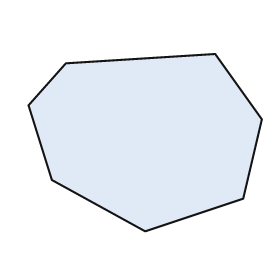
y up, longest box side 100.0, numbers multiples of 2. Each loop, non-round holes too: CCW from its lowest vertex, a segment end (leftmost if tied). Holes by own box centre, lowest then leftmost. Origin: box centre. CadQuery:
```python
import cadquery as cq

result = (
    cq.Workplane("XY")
    .moveTo(0.0, -38.0)
    .lineTo(42.0, -24.0)
    .lineTo(50.0, 10.0)
    .lineTo(30.0, 38.0)
    .lineTo(-34.0, 34.0)
    .lineTo(-50.0, 16.0)
    .lineTo(-40.0, -16.0)
    .close()
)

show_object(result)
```